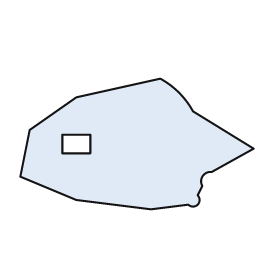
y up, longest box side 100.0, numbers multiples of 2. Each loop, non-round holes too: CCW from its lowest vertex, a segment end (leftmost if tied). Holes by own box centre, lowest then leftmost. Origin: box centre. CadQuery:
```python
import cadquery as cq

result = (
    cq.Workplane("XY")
    .moveTo(6.0, -28.0)
    .lineTo(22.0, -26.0)
    .threePointArc((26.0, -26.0), (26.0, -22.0))
    .lineTo(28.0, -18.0)
    .threePointArc((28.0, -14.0), (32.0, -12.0))
    .lineTo(50.0, -2.0)
    .lineTo(24.0, 14.0)
    .threePointArc((18.0, 22.0), (10.0, 28.0))
    .lineTo(-26.0, 20.0)
    .lineTo(-46.0, 6.0)
    .lineTo(-50.0, -14.0)
    .lineTo(-26.0, -24.0)
    .close()
    .moveTo(-32.0, -4.0)
    .lineTo(-20.0, -4.0)
    .lineTo(-20.0, 4.0)
    .lineTo(-32.0, 4.0)
    .close()
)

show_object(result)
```